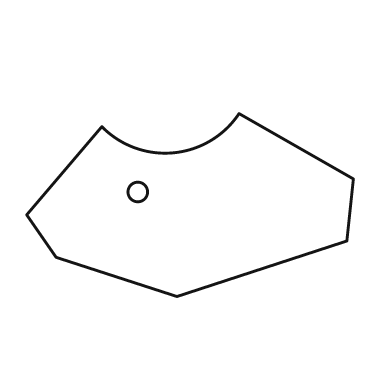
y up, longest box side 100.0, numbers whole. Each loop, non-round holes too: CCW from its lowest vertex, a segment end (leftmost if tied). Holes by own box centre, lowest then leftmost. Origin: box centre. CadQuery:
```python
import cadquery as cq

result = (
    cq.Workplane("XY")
    .moveTo(-4.0, -28.0)
    .lineTo(48.0, -11.0)
    .lineTo(50.0, 8.0)
    .lineTo(15.0, 28.0)
    .threePointArc((-5.0, 16.0), (-27.0, 24.0))
    .lineTo(-50.0, -3.0)
    .lineTo(-41.0, -16.0)
    .close()
    .moveTo(-16.0, 4.0)
    .circle(3.0)
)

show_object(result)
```